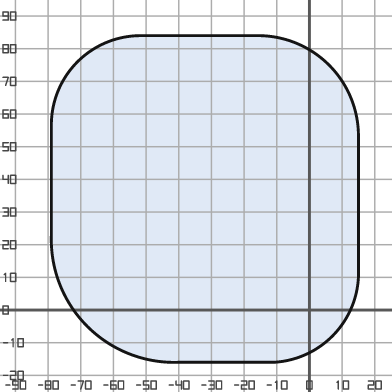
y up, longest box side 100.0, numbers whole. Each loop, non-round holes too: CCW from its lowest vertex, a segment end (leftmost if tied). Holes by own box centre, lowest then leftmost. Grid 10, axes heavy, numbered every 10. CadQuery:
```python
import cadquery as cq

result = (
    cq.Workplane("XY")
    .moveTo(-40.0, -16.0)
    .lineTo(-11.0, -16.0)
    .threePointArc((7.0, -8.0), (15.0, 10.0))
    .lineTo(15.0, 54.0)
    .threePointArc((6.0, 75.0), (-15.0, 84.0))
    .lineTo(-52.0, 84.0)
    .threePointArc((-71.0, 76.0), (-79.0, 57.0))
    .lineTo(-79.0, 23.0)
    .threePointArc((-68.0, -5.0), (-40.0, -16.0))
    .close()
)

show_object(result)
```